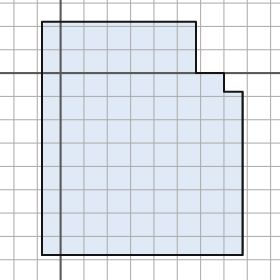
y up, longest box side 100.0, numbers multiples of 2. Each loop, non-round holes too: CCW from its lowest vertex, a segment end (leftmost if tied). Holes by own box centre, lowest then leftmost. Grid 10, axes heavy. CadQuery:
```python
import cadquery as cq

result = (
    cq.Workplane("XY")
    .moveTo(-8.0, -78.0)
    .lineTo(78.0, -78.0)
    .lineTo(78.0, -8.0)
    .lineTo(70.0, -8.0)
    .lineTo(70.0, 0.0)
    .lineTo(58.0, 0.0)
    .lineTo(58.0, 22.0)
    .lineTo(-8.0, 22.0)
    .close()
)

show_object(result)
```